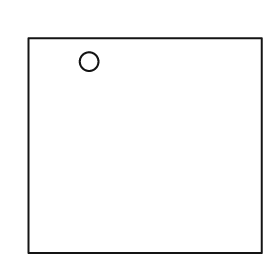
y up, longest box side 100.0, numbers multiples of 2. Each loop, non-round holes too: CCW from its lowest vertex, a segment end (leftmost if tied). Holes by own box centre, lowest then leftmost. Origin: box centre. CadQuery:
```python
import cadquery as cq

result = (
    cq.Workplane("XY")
    .moveTo(-50.0, -46.0)
    .lineTo(50.0, -46.0)
    .lineTo(50.0, 46.0)
    .lineTo(-50.0, 46.0)
    .close()
    .moveTo(-24.0, 36.0)
    .circle(4.0)
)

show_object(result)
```